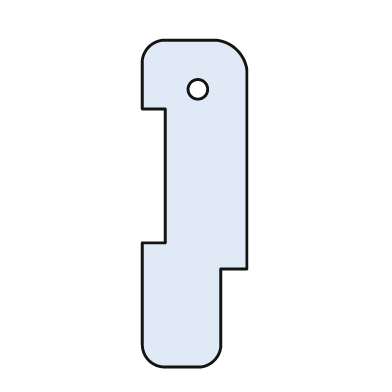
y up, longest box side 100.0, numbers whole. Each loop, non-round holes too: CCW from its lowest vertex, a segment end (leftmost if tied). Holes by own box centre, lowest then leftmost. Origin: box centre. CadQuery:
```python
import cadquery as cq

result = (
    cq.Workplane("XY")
    .moveTo(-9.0, -50.0)
    .lineTo(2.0, -50.0)
    .threePointArc((6.0, -48.0), (8.0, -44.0))
    .lineTo(8.0, -20.0)
    .lineTo(16.0, -20.0)
    .lineTo(16.0, 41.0)
    .threePointArc((13.0, 47.0), (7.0, 50.0))
    .lineTo(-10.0, 50.0)
    .threePointArc((-14.0, 48.0), (-16.0, 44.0))
    .lineTo(-16.0, 29.0)
    .lineTo(-9.0, 29.0)
    .lineTo(-9.0, -12.0)
    .lineTo(-16.0, -12.0)
    .lineTo(-16.0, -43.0)
    .threePointArc((-14.0, -48.0), (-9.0, -50.0))
    .close()
    .moveTo(1.0, 35.0)
    .circle(3.0)
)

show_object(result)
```